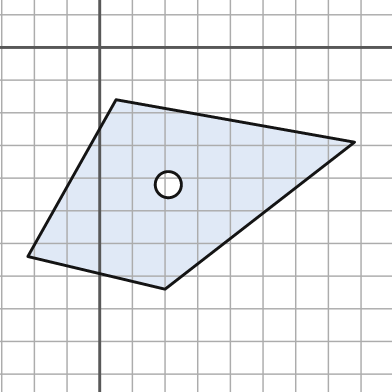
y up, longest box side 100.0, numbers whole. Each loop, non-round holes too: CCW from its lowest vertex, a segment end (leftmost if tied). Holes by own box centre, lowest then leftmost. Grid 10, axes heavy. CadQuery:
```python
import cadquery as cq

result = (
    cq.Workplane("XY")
    .moveTo(20.0, -74.0)
    .lineTo(78.0, -29.0)
    .lineTo(5.0, -16.0)
    .lineTo(-22.0, -64.0)
    .close()
    .moveTo(21.0, -42.0)
    .circle(4.0)
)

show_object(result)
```